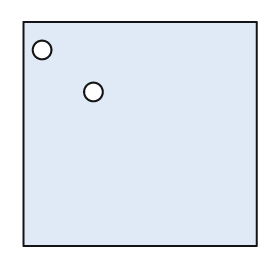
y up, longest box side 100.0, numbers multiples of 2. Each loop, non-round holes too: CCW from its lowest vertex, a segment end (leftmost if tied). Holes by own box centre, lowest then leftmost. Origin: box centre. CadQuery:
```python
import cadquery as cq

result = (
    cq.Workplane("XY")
    .moveTo(-50.0, -48.0)
    .lineTo(50.0, -48.0)
    .lineTo(50.0, 48.0)
    .lineTo(-50.0, 48.0)
    .close()
    .moveTo(-20.0, 18.0)
    .circle(4.0)
    .moveTo(-42.0, 36.0)
    .circle(4.0)
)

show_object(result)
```